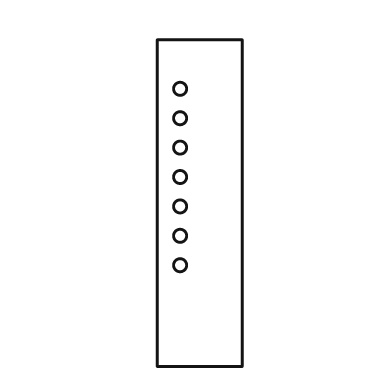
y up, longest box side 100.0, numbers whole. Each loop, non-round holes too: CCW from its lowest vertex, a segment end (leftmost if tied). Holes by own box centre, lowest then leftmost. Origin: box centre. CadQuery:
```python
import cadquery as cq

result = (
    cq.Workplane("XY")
    .moveTo(-13.0, -50.0)
    .lineTo(13.0, -50.0)
    .lineTo(13.0, 50.0)
    .lineTo(-13.0, 50.0)
    .close()
    .moveTo(-6.0, -19.0)
    .circle(2.0)
    .moveTo(-6.0, -10.0)
    .circle(2.0)
    .moveTo(-6.0, -1.0)
    .circle(2.0)
    .moveTo(-6.0, 8.0)
    .circle(2.0)
    .moveTo(-6.0, 17.0)
    .circle(2.0)
    .moveTo(-6.0, 26.0)
    .circle(2.0)
    .moveTo(-6.0, 35.0)
    .circle(2.0)
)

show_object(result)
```